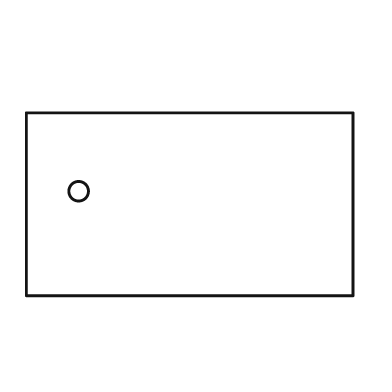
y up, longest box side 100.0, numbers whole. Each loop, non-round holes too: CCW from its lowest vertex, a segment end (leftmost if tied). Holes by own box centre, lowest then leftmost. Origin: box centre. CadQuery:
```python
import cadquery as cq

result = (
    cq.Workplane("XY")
    .moveTo(-50.0, -28.0)
    .lineTo(50.0, -28.0)
    .lineTo(50.0, 28.0)
    .lineTo(-50.0, 28.0)
    .close()
    .moveTo(-34.0, 4.0)
    .circle(3.0)
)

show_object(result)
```